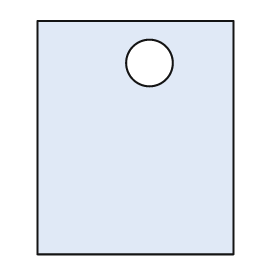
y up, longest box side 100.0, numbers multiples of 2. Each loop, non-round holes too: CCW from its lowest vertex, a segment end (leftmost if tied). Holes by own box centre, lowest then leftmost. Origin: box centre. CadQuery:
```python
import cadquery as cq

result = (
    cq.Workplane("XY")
    .moveTo(-42.0, -50.0)
    .lineTo(42.0, -50.0)
    .lineTo(42.0, 50.0)
    .lineTo(-42.0, 50.0)
    .close()
    .moveTo(6.0, 32.0)
    .circle(10.0)
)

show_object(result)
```